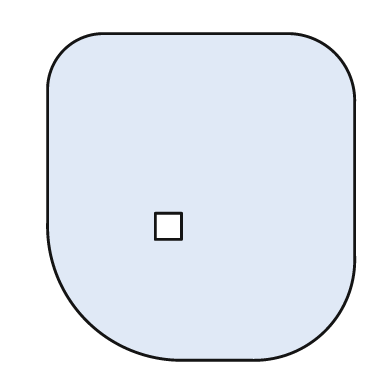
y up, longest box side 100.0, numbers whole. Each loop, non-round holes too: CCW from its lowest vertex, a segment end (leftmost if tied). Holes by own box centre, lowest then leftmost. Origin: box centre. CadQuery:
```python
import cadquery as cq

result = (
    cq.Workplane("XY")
    .moveTo(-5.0, -50.0)
    .lineTo(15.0, -50.0)
    .threePointArc((38.0, -41.0), (47.0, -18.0))
    .lineTo(47.0, 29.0)
    .threePointArc((41.0, 44.0), (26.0, 50.0))
    .lineTo(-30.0, 50.0)
    .threePointArc((-42.0, 45.0), (-47.0, 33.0))
    .lineTo(-47.0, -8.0)
    .threePointArc((-35.0, -38.0), (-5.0, -50.0))
    .close()
    .moveTo(-14.0, -13.0)
    .lineTo(-6.0, -13.0)
    .lineTo(-6.0, -5.0)
    .lineTo(-14.0, -5.0)
    .close()
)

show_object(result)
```